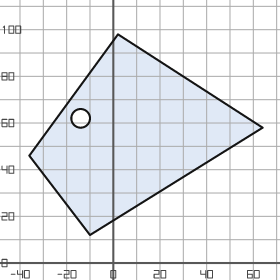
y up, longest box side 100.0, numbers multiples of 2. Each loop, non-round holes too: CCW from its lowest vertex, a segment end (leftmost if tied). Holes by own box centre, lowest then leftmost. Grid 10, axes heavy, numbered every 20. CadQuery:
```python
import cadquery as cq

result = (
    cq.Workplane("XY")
    .moveTo(-10.0, 12.0)
    .lineTo(64.0, 58.0)
    .lineTo(2.0, 98.0)
    .lineTo(-36.0, 46.0)
    .close()
    .moveTo(-14.0, 62.0)
    .circle(4.0)
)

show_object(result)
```